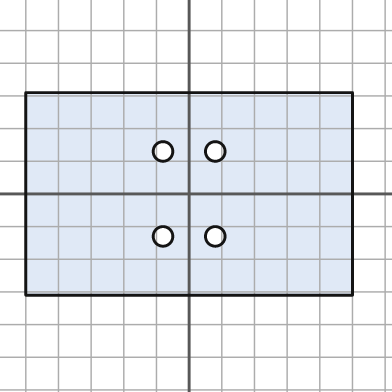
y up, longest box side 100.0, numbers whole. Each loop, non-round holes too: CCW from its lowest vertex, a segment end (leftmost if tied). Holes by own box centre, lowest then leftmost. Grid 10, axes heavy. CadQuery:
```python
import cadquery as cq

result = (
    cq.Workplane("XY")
    .moveTo(-50.0, -31.0)
    .lineTo(50.0, -31.0)
    .lineTo(50.0, 31.0)
    .lineTo(-50.0, 31.0)
    .close()
    .moveTo(-8.0, -13.0)
    .circle(3.0)
    .moveTo(8.0, -13.0)
    .circle(3.0)
    .moveTo(-8.0, 13.0)
    .circle(3.0)
    .moveTo(8.0, 13.0)
    .circle(3.0)
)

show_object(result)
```